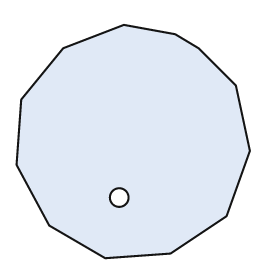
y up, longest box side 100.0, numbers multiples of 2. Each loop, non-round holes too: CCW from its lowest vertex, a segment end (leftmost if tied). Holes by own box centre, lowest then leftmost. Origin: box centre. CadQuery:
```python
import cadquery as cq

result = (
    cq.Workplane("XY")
    .moveTo(-12.0, -50.0)
    .lineTo(16.0, -48.0)
    .lineTo(40.0, -32.0)
    .lineTo(50.0, -4.0)
    .lineTo(44.0, 24.0)
    .lineTo(28.0, 40.0)
    .lineTo(18.0, 46.0)
    .lineTo(-4.0, 50.0)
    .lineTo(-30.0, 40.0)
    .lineTo(-48.0, 18.0)
    .lineTo(-50.0, -10.0)
    .lineTo(-36.0, -36.0)
    .close()
    .moveTo(-6.0, -24.0)
    .circle(4.0)
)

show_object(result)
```